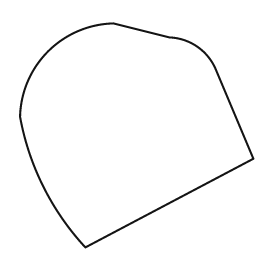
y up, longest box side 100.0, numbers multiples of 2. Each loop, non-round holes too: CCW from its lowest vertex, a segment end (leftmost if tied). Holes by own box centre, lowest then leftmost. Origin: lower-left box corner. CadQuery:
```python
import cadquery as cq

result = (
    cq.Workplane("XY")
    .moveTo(28.0, 0.0)
    .lineTo(100.0, 38.0)
    .lineTo(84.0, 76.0)
    .threePointArc((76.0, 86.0), (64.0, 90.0))
    .lineTo(40.0, 96.0)
    .threePointArc((12.0, 84.0), (0.0, 56.0))
    .threePointArc((10.0, 26.0), (28.0, 0.0))
    .close()
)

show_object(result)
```